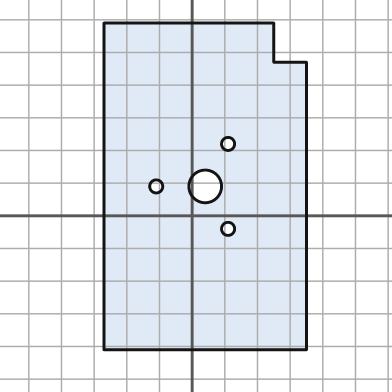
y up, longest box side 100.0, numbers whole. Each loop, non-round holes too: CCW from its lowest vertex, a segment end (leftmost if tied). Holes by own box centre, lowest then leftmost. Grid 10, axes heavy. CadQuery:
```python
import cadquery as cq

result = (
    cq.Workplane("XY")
    .moveTo(-27.0, -41.0)
    .lineTo(35.0, -41.0)
    .lineTo(35.0, 47.0)
    .lineTo(25.0, 47.0)
    .lineTo(25.0, 59.0)
    .lineTo(-27.0, 59.0)
    .close()
    .moveTo(11.0, -4.0)
    .circle(2.0)
    .moveTo(-11.0, 9.0)
    .circle(2.0)
    .moveTo(4.0, 9.0)
    .circle(5.0)
    .moveTo(11.0, 22.0)
    .circle(2.0)
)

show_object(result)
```